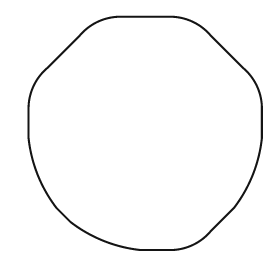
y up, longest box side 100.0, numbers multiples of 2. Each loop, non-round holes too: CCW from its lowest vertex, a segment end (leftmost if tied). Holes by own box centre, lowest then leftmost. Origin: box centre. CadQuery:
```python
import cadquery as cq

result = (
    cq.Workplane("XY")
    .moveTo(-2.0, -50.0)
    .lineTo(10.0, -50.0)
    .threePointArc((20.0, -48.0), (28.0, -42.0))
    .lineTo(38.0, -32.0)
    .threePointArc((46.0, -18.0), (50.0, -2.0))
    .lineTo(50.0, 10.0)
    .threePointArc((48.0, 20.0), (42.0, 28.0))
    .lineTo(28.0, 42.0)
    .threePointArc((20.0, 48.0), (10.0, 50.0))
    .lineTo(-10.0, 50.0)
    .threePointArc((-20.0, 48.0), (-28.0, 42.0))
    .lineTo(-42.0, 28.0)
    .threePointArc((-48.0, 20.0), (-50.0, 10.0))
    .lineTo(-50.0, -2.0)
    .threePointArc((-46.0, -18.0), (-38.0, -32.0))
    .lineTo(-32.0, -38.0)
    .threePointArc((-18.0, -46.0), (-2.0, -50.0))
    .close()
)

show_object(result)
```